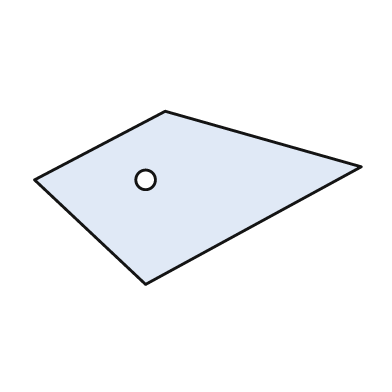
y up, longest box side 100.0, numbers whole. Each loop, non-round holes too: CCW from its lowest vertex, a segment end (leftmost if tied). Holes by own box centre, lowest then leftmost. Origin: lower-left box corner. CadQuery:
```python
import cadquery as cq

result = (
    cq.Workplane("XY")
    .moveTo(34.0, 0.0)
    .lineTo(100.0, 36.0)
    .lineTo(40.0, 53.0)
    .lineTo(0.0, 32.0)
    .close()
    .moveTo(34.0, 32.0)
    .circle(3.0)
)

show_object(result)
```